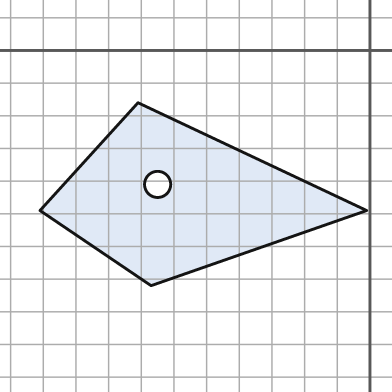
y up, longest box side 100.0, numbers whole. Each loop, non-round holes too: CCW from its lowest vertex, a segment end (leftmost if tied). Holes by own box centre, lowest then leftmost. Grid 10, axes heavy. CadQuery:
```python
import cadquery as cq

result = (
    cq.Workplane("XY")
    .moveTo(-67.0, -72.0)
    .lineTo(-1.0, -49.0)
    .lineTo(-71.0, -16.0)
    .lineTo(-101.0, -49.0)
    .close()
    .moveTo(-65.0, -41.0)
    .circle(4.0)
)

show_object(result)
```